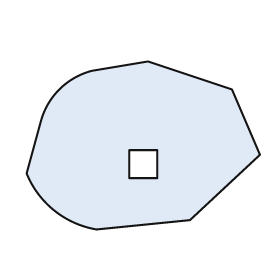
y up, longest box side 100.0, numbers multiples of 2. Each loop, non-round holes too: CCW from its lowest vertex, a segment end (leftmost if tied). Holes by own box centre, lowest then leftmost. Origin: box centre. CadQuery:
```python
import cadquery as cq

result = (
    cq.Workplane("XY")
    .moveTo(-20.0, -36.0)
    .lineTo(20.0, -32.0)
    .lineTo(50.0, -4.0)
    .lineTo(38.0, 24.0)
    .lineTo(2.0, 36.0)
    .lineTo(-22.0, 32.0)
    .threePointArc((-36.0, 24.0), (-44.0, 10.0))
    .lineTo(-50.0, -12.0)
    .threePointArc((-38.0, -28.0), (-20.0, -36.0))
    .close()
    .moveTo(-6.0, -14.0)
    .lineTo(6.0, -14.0)
    .lineTo(6.0, -2.0)
    .lineTo(-6.0, -2.0)
    .close()
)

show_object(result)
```